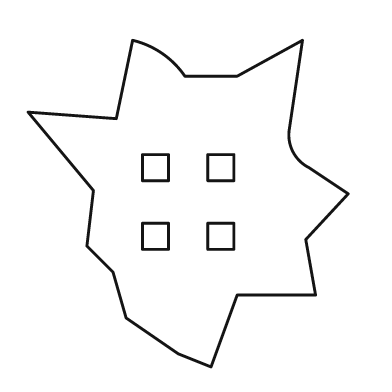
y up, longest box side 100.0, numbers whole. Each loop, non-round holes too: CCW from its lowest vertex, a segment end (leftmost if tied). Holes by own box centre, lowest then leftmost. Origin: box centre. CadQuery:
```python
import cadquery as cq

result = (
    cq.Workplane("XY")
    .moveTo(7.0, -50.0)
    .lineTo(15.0, -28.0)
    .lineTo(39.0, -28.0)
    .lineTo(36.0, -11.0)
    .lineTo(49.0, 3.0)
    .lineTo(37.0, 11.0)
    .threePointArc((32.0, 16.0), (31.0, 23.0))
    .lineTo(35.0, 50.0)
    .lineTo(15.0, 39.0)
    .lineTo(-1.0, 39.0)
    .threePointArc((-8.0, 46.0), (-17.0, 50.0))
    .lineTo(-22.0, 26.0)
    .lineTo(-49.0, 28.0)
    .lineTo(-29.0, 4.0)
    .lineTo(-31.0, -13.0)
    .lineTo(-23.0, -21.0)
    .lineTo(-19.0, -35.0)
    .lineTo(-3.0, -46.0)
    .close()
    .moveTo(-14.0, -14.0)
    .lineTo(-6.0, -14.0)
    .lineTo(-6.0, -6.0)
    .lineTo(-14.0, -6.0)
    .close()
    .moveTo(6.0, -14.0)
    .lineTo(14.0, -14.0)
    .lineTo(14.0, -6.0)
    .lineTo(6.0, -6.0)
    .close()
    .moveTo(-14.0, 7.0)
    .lineTo(-6.0, 7.0)
    .lineTo(-6.0, 15.0)
    .lineTo(-14.0, 15.0)
    .close()
    .moveTo(6.0, 7.0)
    .lineTo(14.0, 7.0)
    .lineTo(14.0, 15.0)
    .lineTo(6.0, 15.0)
    .close()
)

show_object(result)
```